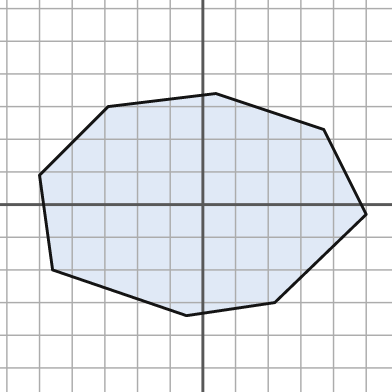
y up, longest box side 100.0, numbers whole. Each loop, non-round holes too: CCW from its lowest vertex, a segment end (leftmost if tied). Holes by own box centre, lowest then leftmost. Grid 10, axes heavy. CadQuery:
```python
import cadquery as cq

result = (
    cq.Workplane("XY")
    .moveTo(-5.0, -34.0)
    .lineTo(22.0, -30.0)
    .lineTo(50.0, -3.0)
    .lineTo(37.0, 23.0)
    .lineTo(4.0, 34.0)
    .lineTo(-29.0, 30.0)
    .lineTo(-50.0, 9.0)
    .lineTo(-46.0, -20.0)
    .close()
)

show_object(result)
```